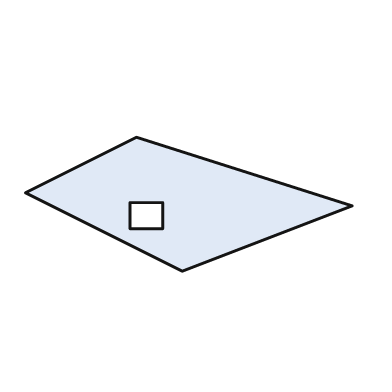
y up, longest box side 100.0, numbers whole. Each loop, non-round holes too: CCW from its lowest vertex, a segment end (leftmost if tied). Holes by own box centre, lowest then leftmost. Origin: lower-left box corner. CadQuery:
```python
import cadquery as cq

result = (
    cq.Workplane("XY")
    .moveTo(48.0, 0.0)
    .lineTo(100.0, 20.0)
    .lineTo(34.0, 41.0)
    .lineTo(0.0, 24.0)
    .close()
    .moveTo(32.0, 13.0)
    .lineTo(42.0, 13.0)
    .lineTo(42.0, 21.0)
    .lineTo(32.0, 21.0)
    .close()
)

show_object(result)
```